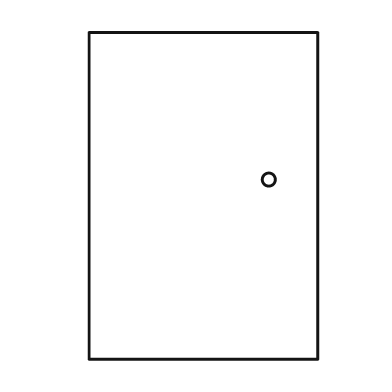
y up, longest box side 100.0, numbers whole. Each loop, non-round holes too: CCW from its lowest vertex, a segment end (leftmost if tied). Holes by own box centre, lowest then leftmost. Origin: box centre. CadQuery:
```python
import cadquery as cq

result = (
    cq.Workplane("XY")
    .moveTo(-35.0, -50.0)
    .lineTo(35.0, -50.0)
    .lineTo(35.0, 50.0)
    .lineTo(-35.0, 50.0)
    .close()
    .moveTo(20.0, 5.0)
    .circle(2.0)
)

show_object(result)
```